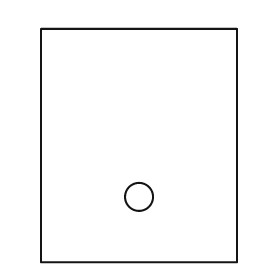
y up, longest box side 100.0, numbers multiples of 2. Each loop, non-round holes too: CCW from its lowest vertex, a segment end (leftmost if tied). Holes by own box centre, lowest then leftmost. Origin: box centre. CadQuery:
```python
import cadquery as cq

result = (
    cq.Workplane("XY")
    .moveTo(-42.0, -50.0)
    .lineTo(42.0, -50.0)
    .lineTo(42.0, 50.0)
    .lineTo(-42.0, 50.0)
    .close()
    .moveTo(0.0, -22.0)
    .circle(6.0)
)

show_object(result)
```